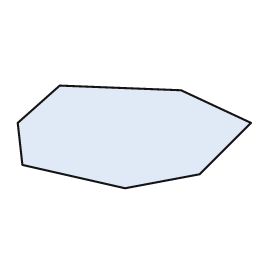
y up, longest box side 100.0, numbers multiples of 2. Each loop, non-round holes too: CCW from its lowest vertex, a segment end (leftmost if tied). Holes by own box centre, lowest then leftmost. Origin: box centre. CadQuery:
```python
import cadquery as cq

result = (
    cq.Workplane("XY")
    .moveTo(-4.0, -22.0)
    .lineTo(28.0, -16.0)
    .lineTo(50.0, 6.0)
    .lineTo(20.0, 20.0)
    .lineTo(-32.0, 22.0)
    .lineTo(-50.0, 6.0)
    .lineTo(-48.0, -12.0)
    .close()
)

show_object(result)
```